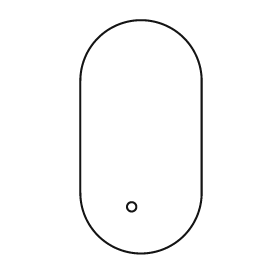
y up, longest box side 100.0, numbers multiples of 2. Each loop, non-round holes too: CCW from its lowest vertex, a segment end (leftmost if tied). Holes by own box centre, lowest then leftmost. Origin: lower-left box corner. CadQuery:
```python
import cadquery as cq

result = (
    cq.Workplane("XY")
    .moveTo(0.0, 26.0)
    .threePointArc((26.0, 0.0), (52.0, 26.0))
    .lineTo(52.0, 74.0)
    .threePointArc((26.0, 100.0), (0.0, 74.0))
    .close()
    .moveTo(22.0, 20.0)
    .circle(2.0)
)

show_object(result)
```